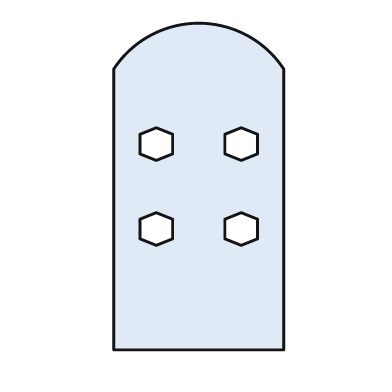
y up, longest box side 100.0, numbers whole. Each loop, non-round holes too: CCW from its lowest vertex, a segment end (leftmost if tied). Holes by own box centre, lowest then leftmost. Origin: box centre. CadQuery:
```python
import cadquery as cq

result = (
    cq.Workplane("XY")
    .moveTo(-26.0, -50.0)
    .lineTo(26.0, -50.0)
    .lineTo(26.0, 36.0)
    .threePointArc((0.0, 50.0), (-26.0, 36.0))
    .close()
    .moveTo(-13.0, -18.0)
    .lineTo(-8.0, -16.0)
    .lineTo(-8.0, -10.0)
    .lineTo(-13.0, -8.0)
    .lineTo(-18.0, -10.0)
    .lineTo(-18.0, -16.0)
    .close()
    .moveTo(13.0, -18.0)
    .lineTo(18.0, -16.0)
    .lineTo(18.0, -10.0)
    .lineTo(13.0, -8.0)
    .lineTo(8.0, -10.0)
    .lineTo(8.0, -16.0)
    .close()
    .moveTo(-13.0, 8.0)
    .lineTo(-8.0, 10.0)
    .lineTo(-8.0, 16.0)
    .lineTo(-13.0, 18.0)
    .lineTo(-18.0, 16.0)
    .lineTo(-18.0, 10.0)
    .close()
    .moveTo(13.0, 8.0)
    .lineTo(18.0, 10.0)
    .lineTo(18.0, 16.0)
    .lineTo(13.0, 18.0)
    .lineTo(8.0, 16.0)
    .lineTo(8.0, 10.0)
    .close()
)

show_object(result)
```